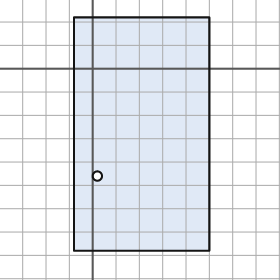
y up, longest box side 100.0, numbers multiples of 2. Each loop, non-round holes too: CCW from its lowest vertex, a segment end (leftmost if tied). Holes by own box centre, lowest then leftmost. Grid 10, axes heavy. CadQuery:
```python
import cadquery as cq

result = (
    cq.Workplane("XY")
    .moveTo(-8.0, -78.0)
    .lineTo(50.0, -78.0)
    .lineTo(50.0, 22.0)
    .lineTo(-8.0, 22.0)
    .close()
    .moveTo(2.0, -46.0)
    .circle(2.0)
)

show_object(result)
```